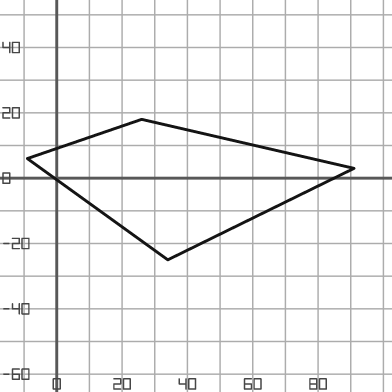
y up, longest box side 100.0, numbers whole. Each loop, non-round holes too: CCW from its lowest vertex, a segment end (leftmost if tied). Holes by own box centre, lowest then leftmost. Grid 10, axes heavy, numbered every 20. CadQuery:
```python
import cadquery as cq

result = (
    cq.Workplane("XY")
    .moveTo(34.0, -25.0)
    .lineTo(91.0, 3.0)
    .lineTo(26.0, 18.0)
    .lineTo(-9.0, 6.0)
    .close()
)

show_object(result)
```